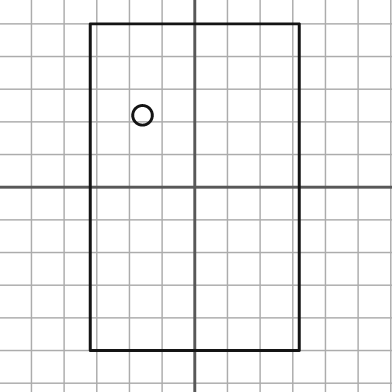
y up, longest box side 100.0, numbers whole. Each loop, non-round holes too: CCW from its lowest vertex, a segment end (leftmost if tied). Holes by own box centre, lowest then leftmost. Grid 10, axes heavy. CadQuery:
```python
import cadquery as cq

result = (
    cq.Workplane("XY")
    .moveTo(-32.0, -50.0)
    .lineTo(32.0, -50.0)
    .lineTo(32.0, 50.0)
    .lineTo(-32.0, 50.0)
    .close()
    .moveTo(-16.0, 22.0)
    .circle(3.0)
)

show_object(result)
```